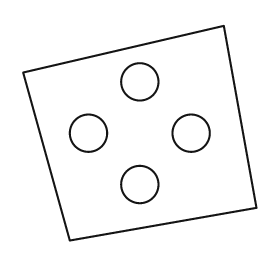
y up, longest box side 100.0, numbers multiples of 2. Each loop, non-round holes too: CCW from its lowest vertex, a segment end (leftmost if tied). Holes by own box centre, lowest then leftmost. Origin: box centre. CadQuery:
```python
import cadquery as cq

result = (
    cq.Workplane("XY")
    .moveTo(-30.0, -46.0)
    .lineTo(50.0, -32.0)
    .lineTo(36.0, 46.0)
    .lineTo(-50.0, 26.0)
    .close()
    .moveTo(0.0, -22.0)
    .circle(8.0)
    .moveTo(-22.0, 0.0)
    .circle(8.0)
    .moveTo(22.0, 0.0)
    .circle(8.0)
    .moveTo(0.0, 22.0)
    .circle(8.0)
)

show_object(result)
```